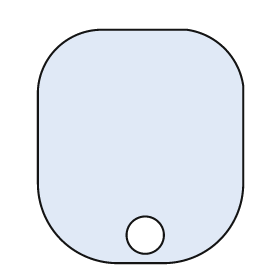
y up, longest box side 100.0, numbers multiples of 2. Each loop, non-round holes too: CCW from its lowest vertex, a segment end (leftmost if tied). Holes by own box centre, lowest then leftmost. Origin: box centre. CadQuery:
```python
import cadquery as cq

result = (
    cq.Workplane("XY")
    .moveTo(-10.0, -50.0)
    .lineTo(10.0, -50.0)
    .threePointArc((34.0, -40.0), (44.0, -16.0))
    .lineTo(44.0, 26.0)
    .threePointArc((36.0, 42.0), (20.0, 50.0))
    .lineTo(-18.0, 50.0)
    .threePointArc((-36.0, 42.0), (-44.0, 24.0))
    .lineTo(-44.0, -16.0)
    .threePointArc((-34.0, -40.0), (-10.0, -50.0))
    .close()
    .moveTo(2.0, -38.0)
    .circle(8.0)
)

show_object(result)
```